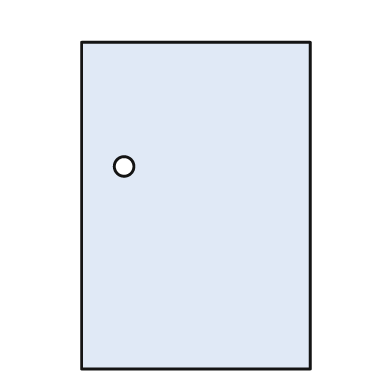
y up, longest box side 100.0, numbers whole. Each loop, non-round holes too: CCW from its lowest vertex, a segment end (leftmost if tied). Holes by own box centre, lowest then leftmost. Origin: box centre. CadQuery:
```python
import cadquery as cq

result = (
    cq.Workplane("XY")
    .moveTo(-35.0, -50.0)
    .lineTo(35.0, -50.0)
    .lineTo(35.0, 50.0)
    .lineTo(-35.0, 50.0)
    .close()
    .moveTo(-22.0, 12.0)
    .circle(3.0)
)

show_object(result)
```